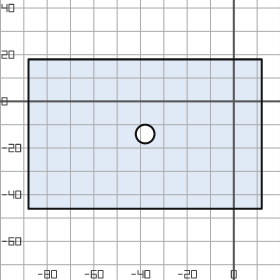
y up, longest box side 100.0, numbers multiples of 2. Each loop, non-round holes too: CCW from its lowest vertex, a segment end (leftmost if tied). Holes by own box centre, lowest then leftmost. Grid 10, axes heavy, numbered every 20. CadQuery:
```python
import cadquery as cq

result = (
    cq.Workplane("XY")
    .moveTo(-88.0, -46.0)
    .lineTo(12.0, -46.0)
    .lineTo(12.0, 18.0)
    .lineTo(-88.0, 18.0)
    .close()
    .moveTo(-38.0, -14.0)
    .circle(4.0)
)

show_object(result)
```